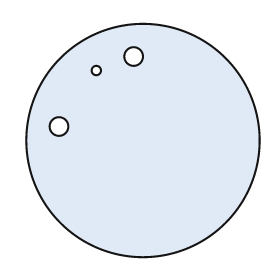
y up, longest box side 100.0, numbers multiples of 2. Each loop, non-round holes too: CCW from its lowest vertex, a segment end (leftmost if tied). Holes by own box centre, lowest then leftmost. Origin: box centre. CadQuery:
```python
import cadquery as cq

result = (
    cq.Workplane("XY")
    .moveTo(0.0, 0.0)
    .circle(50.0)
    .moveTo(-36.0, 6.0)
    .circle(4.0)
    .moveTo(-20.0, 30.0)
    .circle(2.0)
    .moveTo(-4.0, 36.0)
    .circle(4.0)
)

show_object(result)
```